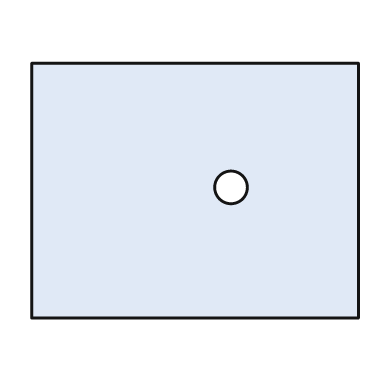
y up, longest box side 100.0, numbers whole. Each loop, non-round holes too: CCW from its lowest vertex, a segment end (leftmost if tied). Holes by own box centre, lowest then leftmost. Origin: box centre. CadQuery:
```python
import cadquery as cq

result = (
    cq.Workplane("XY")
    .moveTo(-50.0, -39.0)
    .lineTo(50.0, -39.0)
    .lineTo(50.0, 39.0)
    .lineTo(-50.0, 39.0)
    .close()
    .moveTo(11.0, 1.0)
    .circle(5.0)
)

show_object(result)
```